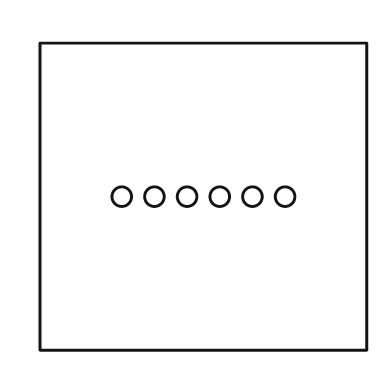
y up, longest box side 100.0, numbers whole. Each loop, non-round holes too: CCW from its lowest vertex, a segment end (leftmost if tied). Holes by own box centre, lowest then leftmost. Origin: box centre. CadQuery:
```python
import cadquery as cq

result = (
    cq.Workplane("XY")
    .moveTo(-50.0, -47.0)
    .lineTo(50.0, -47.0)
    .lineTo(50.0, 47.0)
    .lineTo(-50.0, 47.0)
    .close()
    .moveTo(-25.0, 0.0)
    .circle(3.0)
    .moveTo(-15.0, 0.0)
    .circle(3.0)
    .moveTo(-5.0, 0.0)
    .circle(3.0)
    .moveTo(5.0, 0.0)
    .circle(3.0)
    .moveTo(15.0, 0.0)
    .circle(3.0)
    .moveTo(25.0, 0.0)
    .circle(3.0)
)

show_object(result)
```